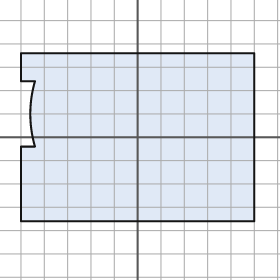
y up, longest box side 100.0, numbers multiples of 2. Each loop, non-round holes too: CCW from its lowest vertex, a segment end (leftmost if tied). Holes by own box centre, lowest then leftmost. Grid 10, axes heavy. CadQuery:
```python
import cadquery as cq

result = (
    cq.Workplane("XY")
    .moveTo(-50.0, -36.0)
    .lineTo(50.0, -36.0)
    .lineTo(50.0, 36.0)
    .lineTo(-50.0, 36.0)
    .lineTo(-50.0, 24.0)
    .lineTo(-44.0, 24.0)
    .threePointArc((-46.0, 10.0), (-44.0, -4.0))
    .lineTo(-50.0, -4.0)
    .close()
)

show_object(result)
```